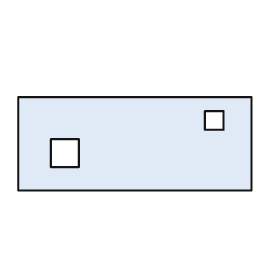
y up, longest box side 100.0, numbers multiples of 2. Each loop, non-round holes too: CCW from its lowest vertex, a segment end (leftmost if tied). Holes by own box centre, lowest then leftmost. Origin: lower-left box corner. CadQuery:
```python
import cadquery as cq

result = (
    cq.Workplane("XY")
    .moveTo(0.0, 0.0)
    .lineTo(100.0, 0.0)
    .lineTo(100.0, 40.0)
    .lineTo(0.0, 40.0)
    .close()
    .moveTo(14.0, 10.0)
    .lineTo(26.0, 10.0)
    .lineTo(26.0, 22.0)
    .lineTo(14.0, 22.0)
    .close()
    .moveTo(80.0, 26.0)
    .lineTo(88.0, 26.0)
    .lineTo(88.0, 34.0)
    .lineTo(80.0, 34.0)
    .close()
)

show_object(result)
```